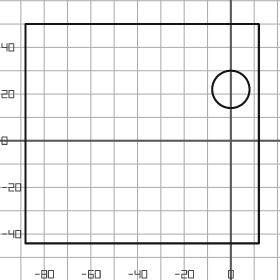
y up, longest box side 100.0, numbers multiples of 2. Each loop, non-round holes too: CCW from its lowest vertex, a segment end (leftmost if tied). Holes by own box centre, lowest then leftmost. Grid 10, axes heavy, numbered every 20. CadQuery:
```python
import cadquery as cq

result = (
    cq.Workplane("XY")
    .moveTo(-88.0, -44.0)
    .lineTo(12.0, -44.0)
    .lineTo(12.0, 50.0)
    .lineTo(-88.0, 50.0)
    .close()
    .moveTo(0.0, 22.0)
    .circle(8.0)
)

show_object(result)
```